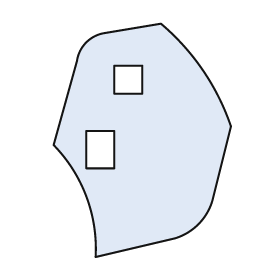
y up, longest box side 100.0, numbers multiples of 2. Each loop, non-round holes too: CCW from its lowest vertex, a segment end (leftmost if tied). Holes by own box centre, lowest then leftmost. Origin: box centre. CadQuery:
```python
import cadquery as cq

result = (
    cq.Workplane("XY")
    .moveTo(-20.0, -50.0)
    .lineTo(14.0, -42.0)
    .threePointArc((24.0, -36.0), (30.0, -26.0))
    .lineTo(38.0, 6.0)
    .threePointArc((26.0, 30.0), (8.0, 50.0))
    .lineTo(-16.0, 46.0)
    .threePointArc((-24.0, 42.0), (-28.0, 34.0))
    .lineTo(-38.0, -2.0)
    .threePointArc((-24.0, -24.0), (-20.0, -50.0))
    .close()
    .moveTo(-24.0, -12.0)
    .lineTo(-12.0, -12.0)
    .lineTo(-12.0, 4.0)
    .lineTo(-24.0, 4.0)
    .close()
    .moveTo(-12.0, 20.0)
    .lineTo(0.0, 20.0)
    .lineTo(0.0, 32.0)
    .lineTo(-12.0, 32.0)
    .close()
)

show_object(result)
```